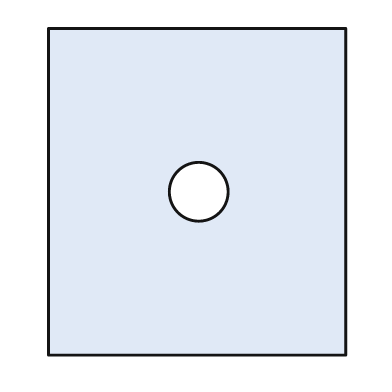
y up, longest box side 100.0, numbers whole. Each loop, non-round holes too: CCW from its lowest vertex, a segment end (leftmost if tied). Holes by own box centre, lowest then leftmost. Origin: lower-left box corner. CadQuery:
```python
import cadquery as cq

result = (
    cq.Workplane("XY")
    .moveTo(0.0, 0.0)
    .lineTo(91.0, 0.0)
    .lineTo(91.0, 100.0)
    .lineTo(0.0, 100.0)
    .close()
    .moveTo(46.0, 50.0)
    .circle(9.0)
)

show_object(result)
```